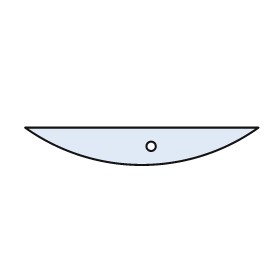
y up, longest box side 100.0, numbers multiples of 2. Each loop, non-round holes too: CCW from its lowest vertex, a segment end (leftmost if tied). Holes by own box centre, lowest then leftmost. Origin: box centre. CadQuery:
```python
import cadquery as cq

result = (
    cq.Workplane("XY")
    .moveTo(-50.0, 8.0)
    .threePointArc((0.0, -8.0), (50.0, 8.0))
    .close()
    .moveTo(4.0, 0.0)
    .circle(2.0)
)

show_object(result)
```